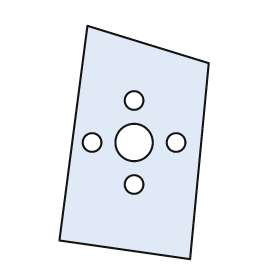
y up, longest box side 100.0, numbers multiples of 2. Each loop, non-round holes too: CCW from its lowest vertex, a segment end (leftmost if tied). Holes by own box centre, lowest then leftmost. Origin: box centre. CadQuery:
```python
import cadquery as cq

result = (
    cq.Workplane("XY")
    .moveTo(24.0, -50.0)
    .lineTo(32.0, 34.0)
    .lineTo(-20.0, 50.0)
    .lineTo(-32.0, -42.0)
    .close()
    .moveTo(0.0, -18.0)
    .circle(4.0)
    .moveTo(-18.0, 0.0)
    .circle(4.0)
    .moveTo(0.0, 0.0)
    .circle(8.0)
    .moveTo(18.0, 0.0)
    .circle(4.0)
    .moveTo(0.0, 18.0)
    .circle(4.0)
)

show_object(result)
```